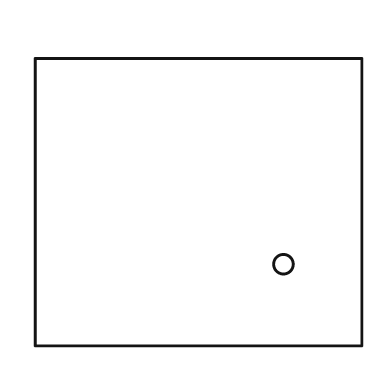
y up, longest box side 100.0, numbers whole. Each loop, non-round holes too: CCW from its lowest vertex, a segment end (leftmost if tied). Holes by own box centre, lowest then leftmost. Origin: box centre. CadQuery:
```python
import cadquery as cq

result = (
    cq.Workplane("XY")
    .moveTo(-50.0, -44.0)
    .lineTo(50.0, -44.0)
    .lineTo(50.0, 44.0)
    .lineTo(-50.0, 44.0)
    .close()
    .moveTo(26.0, -19.0)
    .circle(3.0)
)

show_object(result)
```